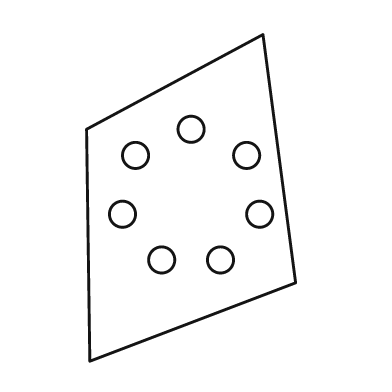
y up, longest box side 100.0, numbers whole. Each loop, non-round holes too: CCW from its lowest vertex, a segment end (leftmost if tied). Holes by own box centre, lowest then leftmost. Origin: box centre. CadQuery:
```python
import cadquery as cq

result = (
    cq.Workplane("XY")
    .moveTo(-31.0, -50.0)
    .lineTo(32.0, -26.0)
    .lineTo(22.0, 50.0)
    .lineTo(-32.0, 21.0)
    .close()
    .moveTo(-9.0, -19.0)
    .circle(4.0)
    .moveTo(9.0, -19.0)
    .circle(4.0)
    .moveTo(-21.0, -5.0)
    .circle(4.0)
    .moveTo(21.0, -5.0)
    .circle(4.0)
    .moveTo(-17.0, 13.0)
    .circle(4.0)
    .moveTo(17.0, 13.0)
    .circle(4.0)
    .moveTo(0.0, 21.0)
    .circle(4.0)
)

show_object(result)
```